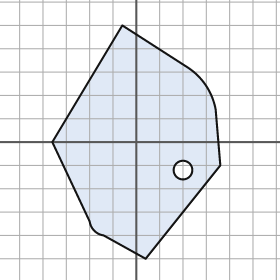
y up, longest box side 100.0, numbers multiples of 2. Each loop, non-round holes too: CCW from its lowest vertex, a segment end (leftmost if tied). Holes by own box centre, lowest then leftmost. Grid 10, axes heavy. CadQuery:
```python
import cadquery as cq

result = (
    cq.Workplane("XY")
    .moveTo(4.0, -50.0)
    .lineTo(36.0, -10.0)
    .lineTo(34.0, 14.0)
    .threePointArc((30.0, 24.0), (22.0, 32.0))
    .lineTo(-6.0, 50.0)
    .lineTo(-36.0, 0.0)
    .lineTo(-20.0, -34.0)
    .threePointArc((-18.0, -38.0), (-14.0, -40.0))
    .close()
    .moveTo(20.0, -12.0)
    .circle(4.0)
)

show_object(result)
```